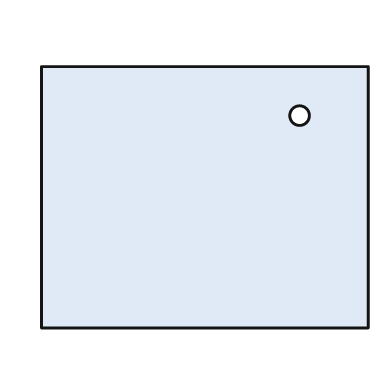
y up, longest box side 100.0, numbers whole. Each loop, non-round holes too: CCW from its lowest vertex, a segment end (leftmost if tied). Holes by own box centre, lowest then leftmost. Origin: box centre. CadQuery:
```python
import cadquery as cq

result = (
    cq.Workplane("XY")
    .moveTo(-50.0, -40.0)
    .lineTo(50.0, -40.0)
    .lineTo(50.0, 40.0)
    .lineTo(-50.0, 40.0)
    .close()
    .moveTo(29.0, 25.0)
    .circle(3.0)
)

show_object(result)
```